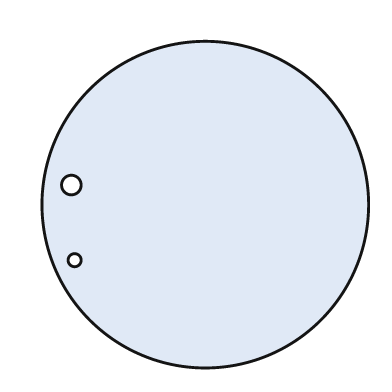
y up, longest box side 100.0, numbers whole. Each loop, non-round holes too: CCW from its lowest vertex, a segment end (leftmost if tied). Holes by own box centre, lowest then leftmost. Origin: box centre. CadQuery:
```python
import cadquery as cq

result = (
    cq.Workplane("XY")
    .moveTo(0.0, 0.0)
    .circle(50.0)
    .moveTo(-40.0, -17.0)
    .circle(2.0)
    .moveTo(-41.0, 6.0)
    .circle(3.0)
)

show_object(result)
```